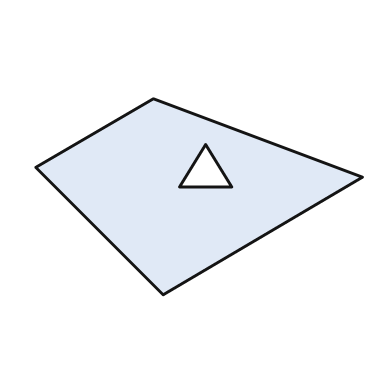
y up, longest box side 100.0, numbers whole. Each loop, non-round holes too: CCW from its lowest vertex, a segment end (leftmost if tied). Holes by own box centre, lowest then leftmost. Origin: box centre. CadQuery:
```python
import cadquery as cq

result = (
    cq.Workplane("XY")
    .moveTo(-11.0, -30.0)
    .lineTo(50.0, 6.0)
    .lineTo(-14.0, 30.0)
    .lineTo(-50.0, 9.0)
    .close()
    .moveTo(-6.0, 3.0)
    .lineTo(10.0, 3.0)
    .lineTo(2.0, 16.0)
    .close()
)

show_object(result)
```